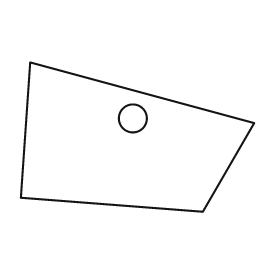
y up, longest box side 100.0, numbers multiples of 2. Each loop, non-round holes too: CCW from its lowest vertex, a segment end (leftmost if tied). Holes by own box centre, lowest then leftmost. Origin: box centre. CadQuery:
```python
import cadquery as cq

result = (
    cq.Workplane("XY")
    .moveTo(28.0, -32.0)
    .lineTo(50.0, 6.0)
    .lineTo(-46.0, 32.0)
    .lineTo(-50.0, -26.0)
    .close()
    .moveTo(-2.0, 8.0)
    .circle(6.0)
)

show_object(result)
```